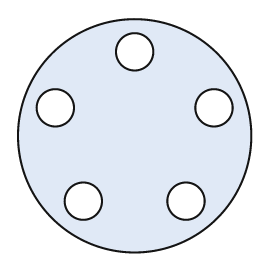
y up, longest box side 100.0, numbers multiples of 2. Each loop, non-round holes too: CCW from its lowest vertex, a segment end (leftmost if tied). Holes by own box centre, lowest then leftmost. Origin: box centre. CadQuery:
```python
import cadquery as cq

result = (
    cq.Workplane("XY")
    .moveTo(0.0, 0.0)
    .circle(50.0)
    .moveTo(-22.0, -28.0)
    .circle(8.0)
    .moveTo(22.0, -28.0)
    .circle(8.0)
    .moveTo(-34.0, 12.0)
    .circle(8.0)
    .moveTo(34.0, 12.0)
    .circle(8.0)
    .moveTo(0.0, 36.0)
    .circle(8.0)
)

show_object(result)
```